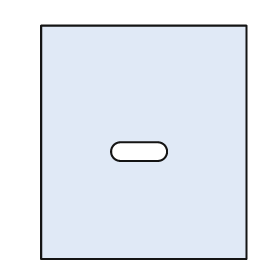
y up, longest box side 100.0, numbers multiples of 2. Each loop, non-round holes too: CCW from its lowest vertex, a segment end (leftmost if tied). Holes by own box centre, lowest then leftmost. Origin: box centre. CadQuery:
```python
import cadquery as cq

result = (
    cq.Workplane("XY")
    .moveTo(-44.0, -50.0)
    .lineTo(44.0, -50.0)
    .lineTo(44.0, 50.0)
    .lineTo(-44.0, 50.0)
    .close()
    .moveTo(-10.0, -8.0)
    .lineTo(6.0, -8.0)
    .threePointArc((10.0, -4.0), (6.0, 0.0))
    .lineTo(-10.0, 0.0)
    .threePointArc((-14.0, -4.0), (-10.0, -8.0))
    .close()
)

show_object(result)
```